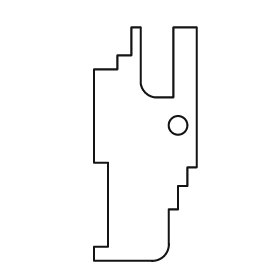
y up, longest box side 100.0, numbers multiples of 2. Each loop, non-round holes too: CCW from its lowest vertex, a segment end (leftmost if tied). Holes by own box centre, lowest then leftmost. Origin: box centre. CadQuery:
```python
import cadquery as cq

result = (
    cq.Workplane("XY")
    .moveTo(-22.0, -50.0)
    .lineTo(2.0, -50.0)
    .threePointArc((8.0, -48.0), (10.0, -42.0))
    .lineTo(10.0, -28.0)
    .lineTo(14.0, -28.0)
    .lineTo(14.0, -18.0)
    .lineTo(18.0, -18.0)
    .lineTo(18.0, -10.0)
    .lineTo(22.0, -10.0)
    .lineTo(22.0, 50.0)
    .lineTo(12.0, 50.0)
    .lineTo(12.0, 20.0)
    .lineTo(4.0, 20.0)
    .threePointArc((0.0, 22.0), (-2.0, 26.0))
    .lineTo(-2.0, 50.0)
    .lineTo(-6.0, 50.0)
    .lineTo(-6.0, 38.0)
    .lineTo(-12.0, 38.0)
    .lineTo(-12.0, 32.0)
    .lineTo(-22.0, 32.0)
    .lineTo(-22.0, -8.0)
    .lineTo(-16.0, -8.0)
    .lineTo(-16.0, -44.0)
    .lineTo(-22.0, -44.0)
    .close()
    .moveTo(14.0, 8.0)
    .circle(4.0)
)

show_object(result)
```